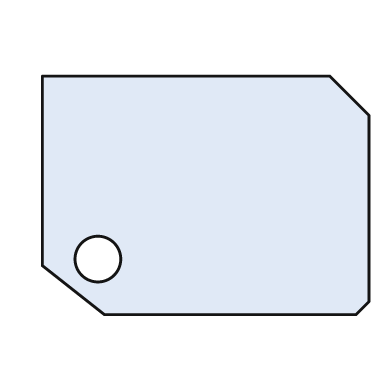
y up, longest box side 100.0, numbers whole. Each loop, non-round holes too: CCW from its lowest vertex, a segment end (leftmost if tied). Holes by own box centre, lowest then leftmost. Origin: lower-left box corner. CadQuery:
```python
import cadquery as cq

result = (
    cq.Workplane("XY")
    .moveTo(19.0, 0.0)
    .lineTo(96.0, 0.0)
    .lineTo(100.0, 4.0)
    .lineTo(100.0, 61.0)
    .lineTo(88.0, 73.0)
    .lineTo(0.0, 73.0)
    .lineTo(0.0, 15.0)
    .close()
    .moveTo(17.0, 17.0)
    .circle(7.0)
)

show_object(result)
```